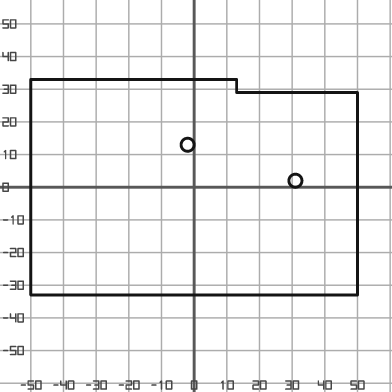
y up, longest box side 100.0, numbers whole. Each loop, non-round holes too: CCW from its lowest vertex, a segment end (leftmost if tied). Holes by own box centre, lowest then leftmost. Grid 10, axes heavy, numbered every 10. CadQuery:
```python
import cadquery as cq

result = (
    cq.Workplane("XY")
    .moveTo(-50.0, -33.0)
    .lineTo(50.0, -33.0)
    .lineTo(50.0, 29.0)
    .lineTo(13.0, 29.0)
    .lineTo(13.0, 33.0)
    .lineTo(-50.0, 33.0)
    .close()
    .moveTo(31.0, 2.0)
    .circle(2.0)
    .moveTo(-2.0, 13.0)
    .circle(2.0)
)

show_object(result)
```